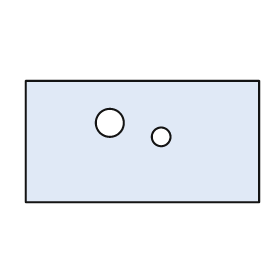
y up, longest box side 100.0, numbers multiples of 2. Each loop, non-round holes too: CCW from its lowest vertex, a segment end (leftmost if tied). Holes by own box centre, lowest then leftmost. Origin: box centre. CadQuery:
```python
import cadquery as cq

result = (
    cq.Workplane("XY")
    .moveTo(-50.0, -26.0)
    .lineTo(50.0, -26.0)
    .lineTo(50.0, 26.0)
    .lineTo(-50.0, 26.0)
    .close()
    .moveTo(8.0, 2.0)
    .circle(4.0)
    .moveTo(-14.0, 8.0)
    .circle(6.0)
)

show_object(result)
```